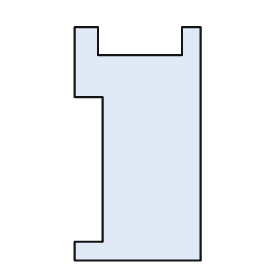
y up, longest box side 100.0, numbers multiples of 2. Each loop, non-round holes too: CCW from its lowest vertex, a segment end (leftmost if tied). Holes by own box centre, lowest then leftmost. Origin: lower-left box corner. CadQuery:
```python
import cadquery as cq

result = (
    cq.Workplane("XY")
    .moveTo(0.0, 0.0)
    .lineTo(54.0, 0.0)
    .lineTo(54.0, 100.0)
    .lineTo(46.0, 100.0)
    .lineTo(46.0, 88.0)
    .lineTo(10.0, 88.0)
    .lineTo(10.0, 100.0)
    .lineTo(0.0, 100.0)
    .lineTo(0.0, 70.0)
    .lineTo(12.0, 70.0)
    .lineTo(12.0, 8.0)
    .lineTo(0.0, 8.0)
    .close()
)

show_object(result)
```